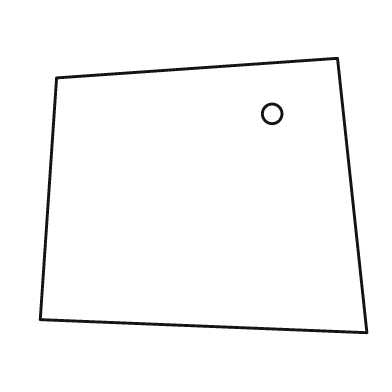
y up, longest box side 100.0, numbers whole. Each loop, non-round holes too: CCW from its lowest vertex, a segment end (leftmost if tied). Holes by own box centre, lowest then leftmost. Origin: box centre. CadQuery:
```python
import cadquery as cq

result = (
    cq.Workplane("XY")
    .moveTo(50.0, -42.0)
    .lineTo(41.0, 42.0)
    .lineTo(-45.0, 36.0)
    .lineTo(-50.0, -38.0)
    .close()
    .moveTo(21.0, 25.0)
    .circle(3.0)
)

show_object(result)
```